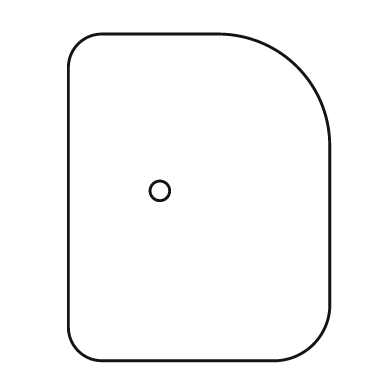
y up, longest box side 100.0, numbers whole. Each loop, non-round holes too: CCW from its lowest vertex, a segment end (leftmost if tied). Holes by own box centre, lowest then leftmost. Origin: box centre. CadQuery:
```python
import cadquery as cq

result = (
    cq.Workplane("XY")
    .moveTo(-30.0, -50.0)
    .lineTo(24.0, -50.0)
    .threePointArc((35.0, -45.0), (40.0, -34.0))
    .lineTo(40.0, 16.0)
    .threePointArc((30.0, 40.0), (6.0, 50.0))
    .lineTo(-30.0, 50.0)
    .threePointArc((-37.0, 47.0), (-40.0, 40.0))
    .lineTo(-40.0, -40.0)
    .threePointArc((-37.0, -47.0), (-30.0, -50.0))
    .close()
    .moveTo(-12.0, 2.0)
    .circle(3.0)
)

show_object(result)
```